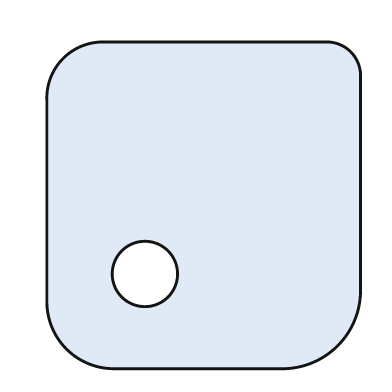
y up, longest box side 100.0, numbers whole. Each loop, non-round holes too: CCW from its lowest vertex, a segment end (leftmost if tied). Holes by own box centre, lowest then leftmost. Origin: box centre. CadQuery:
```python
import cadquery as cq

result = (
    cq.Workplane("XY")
    .moveTo(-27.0, -50.0)
    .lineTo(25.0, -50.0)
    .threePointArc((41.0, -43.0), (48.0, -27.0))
    .lineTo(48.0, 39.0)
    .threePointArc((45.0, 47.0), (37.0, 50.0))
    .lineTo(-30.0, 50.0)
    .threePointArc((-43.0, 45.0), (-48.0, 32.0))
    .lineTo(-48.0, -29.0)
    .threePointArc((-42.0, -44.0), (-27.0, -50.0))
    .close()
    .moveTo(-18.0, -21.0)
    .circle(10.0)
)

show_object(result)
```